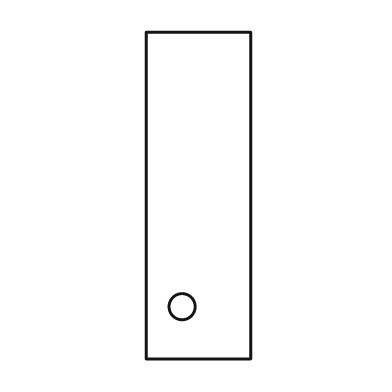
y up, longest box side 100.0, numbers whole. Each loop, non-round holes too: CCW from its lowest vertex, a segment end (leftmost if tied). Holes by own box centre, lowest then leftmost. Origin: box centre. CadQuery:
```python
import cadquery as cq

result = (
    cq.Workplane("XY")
    .moveTo(-16.0, -50.0)
    .lineTo(16.0, -50.0)
    .lineTo(16.0, 50.0)
    .lineTo(-16.0, 50.0)
    .close()
    .moveTo(-5.0, -34.0)
    .circle(4.0)
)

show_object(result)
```